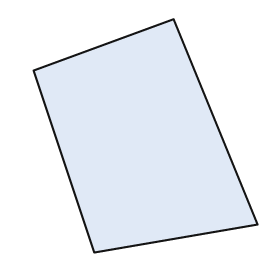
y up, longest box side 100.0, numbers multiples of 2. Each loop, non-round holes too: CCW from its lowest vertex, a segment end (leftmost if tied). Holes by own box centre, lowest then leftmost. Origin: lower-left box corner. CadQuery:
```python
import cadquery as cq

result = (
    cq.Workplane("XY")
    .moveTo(26.0, 0.0)
    .lineTo(96.0, 12.0)
    .lineTo(60.0, 100.0)
    .lineTo(0.0, 78.0)
    .close()
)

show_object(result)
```